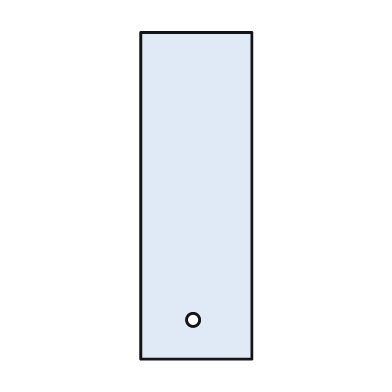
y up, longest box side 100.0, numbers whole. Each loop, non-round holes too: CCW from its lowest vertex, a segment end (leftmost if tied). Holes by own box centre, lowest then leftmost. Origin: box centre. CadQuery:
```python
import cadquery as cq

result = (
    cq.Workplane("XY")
    .moveTo(-17.0, -50.0)
    .lineTo(17.0, -50.0)
    .lineTo(17.0, 50.0)
    .lineTo(-17.0, 50.0)
    .close()
    .moveTo(-1.0, -38.0)
    .circle(2.0)
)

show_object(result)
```